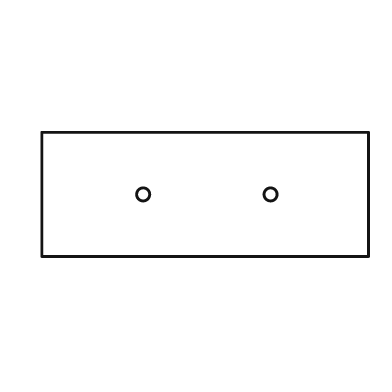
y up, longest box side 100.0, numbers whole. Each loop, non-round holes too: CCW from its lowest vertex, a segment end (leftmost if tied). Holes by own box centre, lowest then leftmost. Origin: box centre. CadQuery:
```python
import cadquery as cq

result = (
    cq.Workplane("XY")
    .moveTo(-50.0, -19.0)
    .lineTo(50.0, -19.0)
    .lineTo(50.0, 19.0)
    .lineTo(-50.0, 19.0)
    .close()
    .moveTo(-19.0, 0.0)
    .circle(2.0)
    .moveTo(20.0, 0.0)
    .circle(2.0)
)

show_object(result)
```